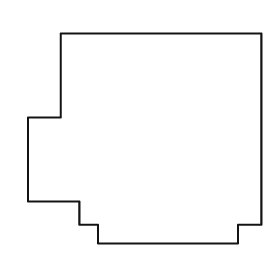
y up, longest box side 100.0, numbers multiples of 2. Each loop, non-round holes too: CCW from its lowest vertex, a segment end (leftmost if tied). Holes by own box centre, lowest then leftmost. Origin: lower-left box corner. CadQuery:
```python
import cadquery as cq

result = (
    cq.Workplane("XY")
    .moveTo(30.0, 0.0)
    .lineTo(90.0, 0.0)
    .lineTo(90.0, 8.0)
    .lineTo(100.0, 8.0)
    .lineTo(100.0, 90.0)
    .lineTo(14.0, 90.0)
    .lineTo(14.0, 54.0)
    .lineTo(0.0, 54.0)
    .lineTo(0.0, 18.0)
    .lineTo(22.0, 18.0)
    .lineTo(22.0, 8.0)
    .lineTo(30.0, 8.0)
    .close()
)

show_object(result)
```